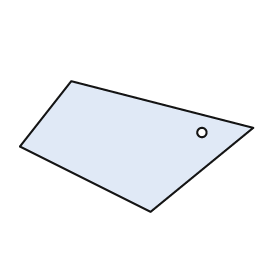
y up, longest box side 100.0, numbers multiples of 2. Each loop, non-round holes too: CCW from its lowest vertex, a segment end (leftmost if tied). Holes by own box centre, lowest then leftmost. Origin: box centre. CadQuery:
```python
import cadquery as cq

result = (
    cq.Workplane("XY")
    .moveTo(6.0, -28.0)
    .lineTo(50.0, 8.0)
    .lineTo(-28.0, 28.0)
    .lineTo(-50.0, 0.0)
    .close()
    .moveTo(28.0, 6.0)
    .circle(2.0)
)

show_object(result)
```